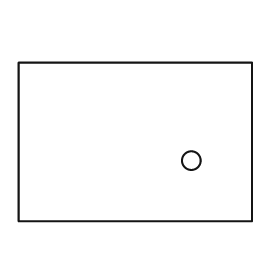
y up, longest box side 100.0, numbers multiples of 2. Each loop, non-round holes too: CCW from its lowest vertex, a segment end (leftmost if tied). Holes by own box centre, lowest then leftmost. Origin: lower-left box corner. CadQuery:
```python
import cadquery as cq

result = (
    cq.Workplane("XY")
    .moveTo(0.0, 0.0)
    .lineTo(100.0, 0.0)
    .lineTo(100.0, 68.0)
    .lineTo(0.0, 68.0)
    .close()
    .moveTo(74.0, 26.0)
    .circle(4.0)
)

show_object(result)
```